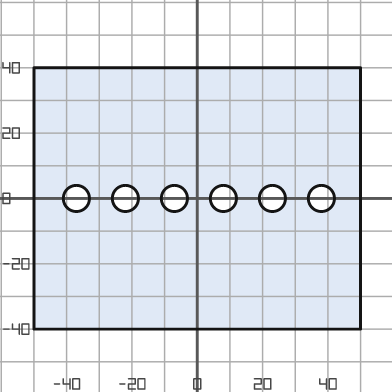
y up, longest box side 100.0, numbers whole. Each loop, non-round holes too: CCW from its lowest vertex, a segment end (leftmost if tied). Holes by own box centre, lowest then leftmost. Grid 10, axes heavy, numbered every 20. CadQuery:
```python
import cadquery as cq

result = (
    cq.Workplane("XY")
    .moveTo(-50.0, -40.0)
    .lineTo(50.0, -40.0)
    .lineTo(50.0, 40.0)
    .lineTo(-50.0, 40.0)
    .close()
    .moveTo(-37.0, 0.0)
    .circle(4.0)
    .moveTo(-22.0, 0.0)
    .circle(4.0)
    .moveTo(-7.0, 0.0)
    .circle(4.0)
    .moveTo(8.0, 0.0)
    .circle(4.0)
    .moveTo(23.0, 0.0)
    .circle(4.0)
    .moveTo(38.0, 0.0)
    .circle(4.0)
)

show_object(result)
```